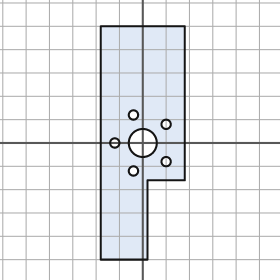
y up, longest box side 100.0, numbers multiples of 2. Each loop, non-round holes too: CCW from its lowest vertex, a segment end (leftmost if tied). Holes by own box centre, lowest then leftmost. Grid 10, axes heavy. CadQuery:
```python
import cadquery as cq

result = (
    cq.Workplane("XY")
    .moveTo(-18.0, -50.0)
    .lineTo(2.0, -50.0)
    .lineTo(2.0, -16.0)
    .lineTo(18.0, -16.0)
    .lineTo(18.0, 50.0)
    .lineTo(-18.0, 50.0)
    .close()
    .moveTo(-4.0, -12.0)
    .circle(2.0)
    .moveTo(10.0, -8.0)
    .circle(2.0)
    .moveTo(-12.0, 0.0)
    .circle(2.0)
    .moveTo(0.0, 0.0)
    .circle(6.0)
    .moveTo(10.0, 8.0)
    .circle(2.0)
    .moveTo(-4.0, 12.0)
    .circle(2.0)
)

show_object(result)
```